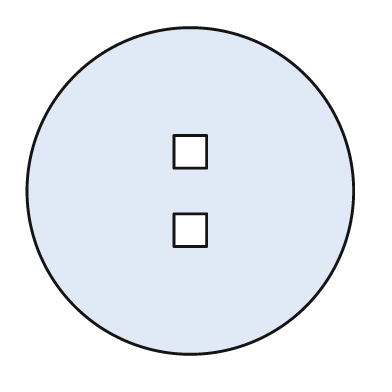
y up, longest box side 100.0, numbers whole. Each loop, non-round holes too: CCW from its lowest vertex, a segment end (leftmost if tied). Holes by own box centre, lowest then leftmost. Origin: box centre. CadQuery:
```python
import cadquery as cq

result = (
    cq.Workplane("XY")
    .moveTo(0.0, 0.0)
    .circle(50.0)
    .moveTo(-5.0, -17.0)
    .lineTo(5.0, -17.0)
    .lineTo(5.0, -7.0)
    .lineTo(-5.0, -7.0)
    .close()
    .moveTo(-5.0, 7.0)
    .lineTo(5.0, 7.0)
    .lineTo(5.0, 17.0)
    .lineTo(-5.0, 17.0)
    .close()
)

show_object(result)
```